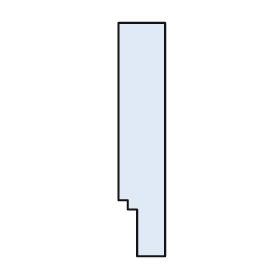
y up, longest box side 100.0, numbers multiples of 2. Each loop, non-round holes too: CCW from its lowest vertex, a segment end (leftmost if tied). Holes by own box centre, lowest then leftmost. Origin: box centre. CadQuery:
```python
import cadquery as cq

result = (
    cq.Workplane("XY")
    .moveTo(-2.0, -50.0)
    .lineTo(10.0, -50.0)
    .lineTo(10.0, 50.0)
    .lineTo(-10.0, 50.0)
    .lineTo(-10.0, -26.0)
    .lineTo(-6.0, -26.0)
    .lineTo(-6.0, -30.0)
    .lineTo(-2.0, -30.0)
    .close()
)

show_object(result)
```